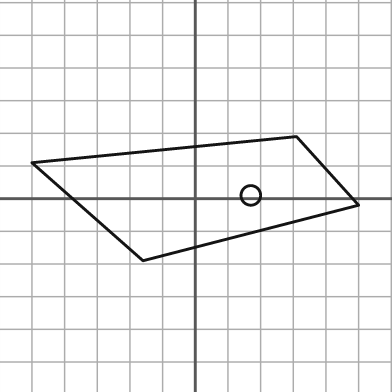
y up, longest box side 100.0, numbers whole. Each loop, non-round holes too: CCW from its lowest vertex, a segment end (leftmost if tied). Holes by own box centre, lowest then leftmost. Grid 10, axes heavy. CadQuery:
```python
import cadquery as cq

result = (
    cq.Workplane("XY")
    .moveTo(-16.0, -19.0)
    .lineTo(50.0, -2.0)
    .lineTo(31.0, 19.0)
    .lineTo(-50.0, 11.0)
    .close()
    .moveTo(17.0, 1.0)
    .circle(3.0)
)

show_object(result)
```